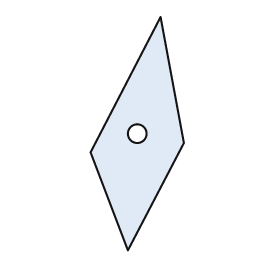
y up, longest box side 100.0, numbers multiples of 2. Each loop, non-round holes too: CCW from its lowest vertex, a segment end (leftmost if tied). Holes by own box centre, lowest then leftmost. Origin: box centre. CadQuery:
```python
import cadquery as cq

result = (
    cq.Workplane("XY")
    .moveTo(-4.0, -50.0)
    .lineTo(20.0, -4.0)
    .lineTo(10.0, 50.0)
    .lineTo(-20.0, -8.0)
    .close()
    .moveTo(0.0, 0.0)
    .circle(4.0)
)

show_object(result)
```